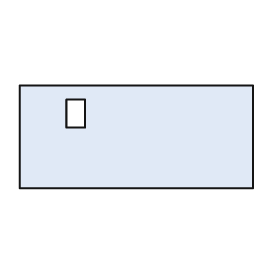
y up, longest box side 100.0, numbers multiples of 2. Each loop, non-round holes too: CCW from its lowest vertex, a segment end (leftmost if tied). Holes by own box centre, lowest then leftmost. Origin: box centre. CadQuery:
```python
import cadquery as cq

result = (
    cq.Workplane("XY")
    .moveTo(-50.0, -22.0)
    .lineTo(50.0, -22.0)
    .lineTo(50.0, 22.0)
    .lineTo(-50.0, 22.0)
    .close()
    .moveTo(-30.0, 4.0)
    .lineTo(-22.0, 4.0)
    .lineTo(-22.0, 16.0)
    .lineTo(-30.0, 16.0)
    .close()
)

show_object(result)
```